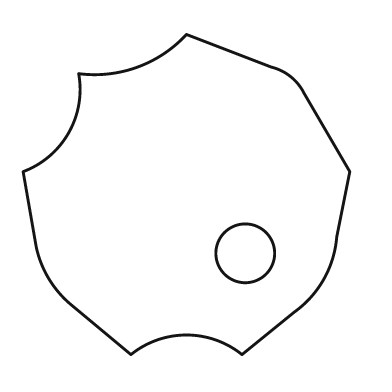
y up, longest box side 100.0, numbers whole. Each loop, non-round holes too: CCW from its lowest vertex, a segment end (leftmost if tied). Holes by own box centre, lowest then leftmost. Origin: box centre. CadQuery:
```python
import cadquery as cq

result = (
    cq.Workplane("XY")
    .moveTo(-17.0, -49.0)
    .threePointArc((0.0, -43.0), (17.0, -49.0))
    .lineTo(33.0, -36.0)
    .threePointArc((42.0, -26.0), (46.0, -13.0))
    .lineTo(50.0, 7.0)
    .lineTo(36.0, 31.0)
    .threePointArc((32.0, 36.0), (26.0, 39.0))
    .lineTo(0.0, 49.0)
    .threePointArc((-15.0, 39.0), (-33.0, 37.0))
    .threePointArc((-36.0, 19.0), (-50.0, 7.0))
    .lineTo(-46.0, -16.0)
    .threePointArc((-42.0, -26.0), (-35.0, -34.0))
    .close()
    .moveTo(18.0, -18.0)
    .circle(9.0)
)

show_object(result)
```